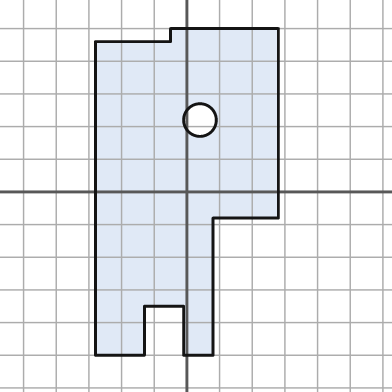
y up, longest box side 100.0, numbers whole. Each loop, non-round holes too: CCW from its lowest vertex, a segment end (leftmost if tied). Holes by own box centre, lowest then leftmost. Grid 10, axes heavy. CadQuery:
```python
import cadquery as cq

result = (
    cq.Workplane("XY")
    .moveTo(-28.0, -50.0)
    .lineTo(-13.0, -50.0)
    .lineTo(-13.0, -35.0)
    .lineTo(-1.0, -35.0)
    .lineTo(-1.0, -50.0)
    .lineTo(8.0, -50.0)
    .lineTo(8.0, -8.0)
    .lineTo(28.0, -8.0)
    .lineTo(28.0, 50.0)
    .lineTo(-5.0, 50.0)
    .lineTo(-5.0, 46.0)
    .lineTo(-28.0, 46.0)
    .close()
    .moveTo(4.0, 22.0)
    .circle(5.0)
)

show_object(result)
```